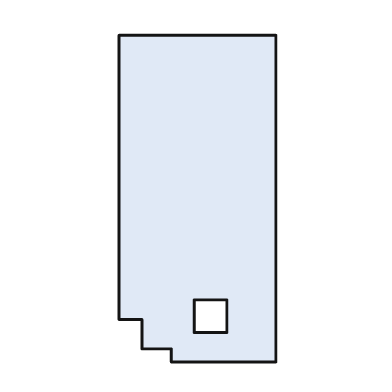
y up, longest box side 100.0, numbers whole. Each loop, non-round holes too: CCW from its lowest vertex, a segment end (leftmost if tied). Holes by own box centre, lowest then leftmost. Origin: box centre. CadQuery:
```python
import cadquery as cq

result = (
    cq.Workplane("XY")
    .moveTo(-8.0, -50.0)
    .lineTo(24.0, -50.0)
    .lineTo(24.0, 50.0)
    .lineTo(-24.0, 50.0)
    .lineTo(-24.0, -37.0)
    .lineTo(-17.0, -37.0)
    .lineTo(-17.0, -46.0)
    .lineTo(-8.0, -46.0)
    .close()
    .moveTo(-1.0, -41.0)
    .lineTo(9.0, -41.0)
    .lineTo(9.0, -31.0)
    .lineTo(-1.0, -31.0)
    .close()
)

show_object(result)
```